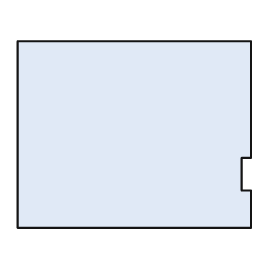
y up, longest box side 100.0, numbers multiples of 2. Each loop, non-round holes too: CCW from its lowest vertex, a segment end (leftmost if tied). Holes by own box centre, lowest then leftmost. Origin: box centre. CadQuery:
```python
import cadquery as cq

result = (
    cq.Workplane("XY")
    .moveTo(-50.0, -40.0)
    .lineTo(50.0, -40.0)
    .lineTo(50.0, -24.0)
    .lineTo(46.0, -24.0)
    .lineTo(46.0, -10.0)
    .lineTo(50.0, -10.0)
    .lineTo(50.0, 40.0)
    .lineTo(-50.0, 40.0)
    .close()
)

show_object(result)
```